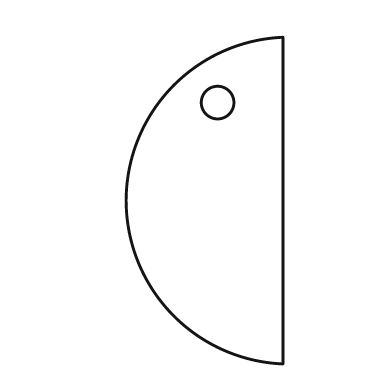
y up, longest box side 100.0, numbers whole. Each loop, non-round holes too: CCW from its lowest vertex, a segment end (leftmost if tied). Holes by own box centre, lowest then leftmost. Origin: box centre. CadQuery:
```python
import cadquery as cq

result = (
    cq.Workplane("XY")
    .moveTo(24.0, -50.0)
    .lineTo(24.0, 50.0)
    .threePointArc((-24.0, 0.0), (24.0, -50.0))
    .close()
    .moveTo(4.0, 30.0)
    .circle(5.0)
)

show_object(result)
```